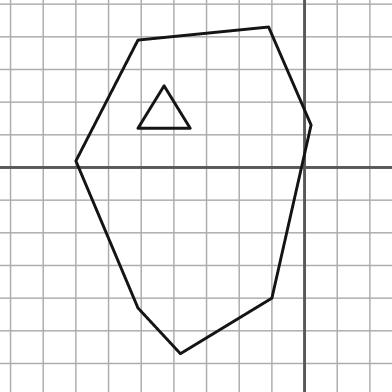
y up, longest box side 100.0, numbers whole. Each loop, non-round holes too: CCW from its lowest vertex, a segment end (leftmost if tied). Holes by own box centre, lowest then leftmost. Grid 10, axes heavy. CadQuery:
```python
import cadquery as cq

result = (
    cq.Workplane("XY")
    .moveTo(-38.0, -57.0)
    .lineTo(-10.0, -40.0)
    .lineTo(2.0, 13.0)
    .lineTo(-11.0, 43.0)
    .lineTo(-51.0, 39.0)
    .lineTo(-70.0, 2.0)
    .lineTo(-51.0, -43.0)
    .close()
    .moveTo(-51.0, 12.0)
    .lineTo(-35.0, 12.0)
    .lineTo(-43.0, 25.0)
    .close()
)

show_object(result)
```